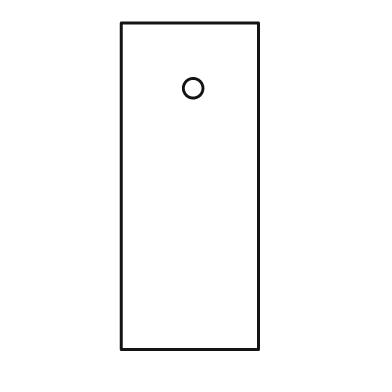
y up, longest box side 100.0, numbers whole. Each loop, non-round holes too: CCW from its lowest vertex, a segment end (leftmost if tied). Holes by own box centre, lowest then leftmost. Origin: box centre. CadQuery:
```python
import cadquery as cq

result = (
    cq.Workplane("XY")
    .moveTo(-21.0, -50.0)
    .lineTo(21.0, -50.0)
    .lineTo(21.0, 50.0)
    .lineTo(-21.0, 50.0)
    .close()
    .moveTo(1.0, 30.0)
    .circle(3.0)
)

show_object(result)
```